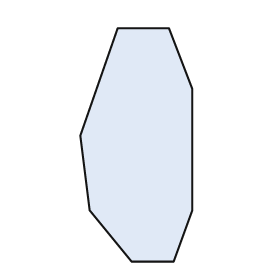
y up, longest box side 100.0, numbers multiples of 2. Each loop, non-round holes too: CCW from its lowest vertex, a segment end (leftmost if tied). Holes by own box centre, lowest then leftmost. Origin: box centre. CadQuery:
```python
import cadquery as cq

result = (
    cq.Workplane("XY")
    .moveTo(-2.0, -50.0)
    .lineTo(16.0, -50.0)
    .lineTo(24.0, -28.0)
    .lineTo(24.0, 24.0)
    .lineTo(14.0, 50.0)
    .lineTo(-8.0, 50.0)
    .lineTo(-24.0, 4.0)
    .lineTo(-20.0, -28.0)
    .close()
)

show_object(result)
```